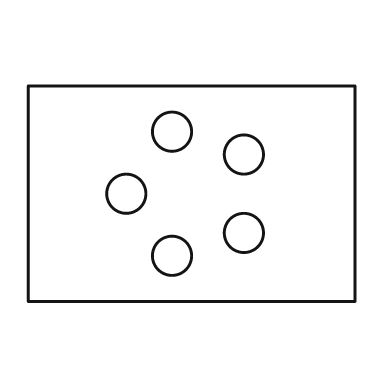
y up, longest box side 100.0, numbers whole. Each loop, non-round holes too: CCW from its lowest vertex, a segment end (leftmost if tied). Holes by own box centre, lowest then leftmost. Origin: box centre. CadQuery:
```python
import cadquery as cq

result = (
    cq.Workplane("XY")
    .moveTo(-50.0, -33.0)
    .lineTo(50.0, -33.0)
    .lineTo(50.0, 33.0)
    .lineTo(-50.0, 33.0)
    .close()
    .moveTo(-6.0, -19.0)
    .circle(6.0)
    .moveTo(16.0, -12.0)
    .circle(6.0)
    .moveTo(-20.0, 0.0)
    .circle(6.0)
    .moveTo(16.0, 12.0)
    .circle(6.0)
    .moveTo(-6.0, 19.0)
    .circle(6.0)
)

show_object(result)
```